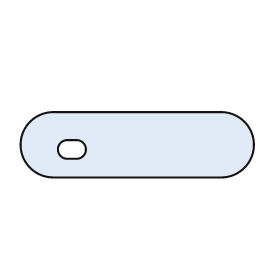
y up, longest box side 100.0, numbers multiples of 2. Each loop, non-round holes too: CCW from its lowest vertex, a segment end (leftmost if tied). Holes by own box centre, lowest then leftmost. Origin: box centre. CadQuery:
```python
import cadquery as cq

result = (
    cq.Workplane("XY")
    .moveTo(-36.0, -14.0)
    .lineTo(36.0, -14.0)
    .threePointArc((50.0, 0.0), (36.0, 14.0))
    .lineTo(-36.0, 14.0)
    .threePointArc((-50.0, 0.0), (-36.0, -14.0))
    .close()
    .moveTo(-30.0, -6.0)
    .lineTo(-26.0, -6.0)
    .threePointArc((-22.0, -2.0), (-26.0, 2.0))
    .lineTo(-30.0, 2.0)
    .threePointArc((-34.0, -2.0), (-30.0, -6.0))
    .close()
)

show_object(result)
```